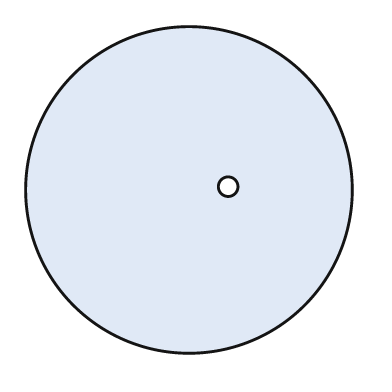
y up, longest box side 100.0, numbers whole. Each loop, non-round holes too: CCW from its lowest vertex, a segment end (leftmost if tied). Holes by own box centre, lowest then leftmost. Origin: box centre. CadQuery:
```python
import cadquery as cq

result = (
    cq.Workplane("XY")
    .moveTo(0.0, 0.0)
    .circle(50.0)
    .moveTo(12.0, 1.0)
    .circle(3.0)
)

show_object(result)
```